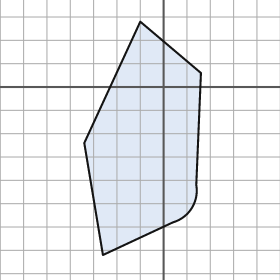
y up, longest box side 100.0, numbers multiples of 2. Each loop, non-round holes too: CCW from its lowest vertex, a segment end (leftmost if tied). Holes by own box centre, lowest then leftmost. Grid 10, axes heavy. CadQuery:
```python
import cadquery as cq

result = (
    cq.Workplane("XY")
    .moveTo(-26.0, -72.0)
    .lineTo(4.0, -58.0)
    .threePointArc((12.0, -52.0), (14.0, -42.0))
    .lineTo(16.0, 6.0)
    .lineTo(-10.0, 28.0)
    .lineTo(-34.0, -24.0)
    .close()
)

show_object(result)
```